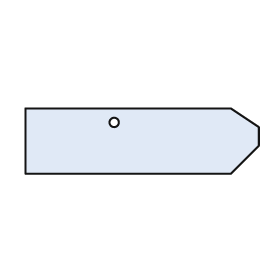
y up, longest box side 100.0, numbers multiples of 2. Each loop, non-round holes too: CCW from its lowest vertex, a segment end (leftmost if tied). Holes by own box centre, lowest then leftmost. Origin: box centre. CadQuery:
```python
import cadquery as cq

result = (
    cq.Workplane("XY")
    .moveTo(-50.0, -14.0)
    .lineTo(38.0, -14.0)
    .lineTo(50.0, -2.0)
    .lineTo(50.0, 6.0)
    .lineTo(38.0, 14.0)
    .lineTo(-50.0, 14.0)
    .close()
    .moveTo(-12.0, 8.0)
    .circle(2.0)
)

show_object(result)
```